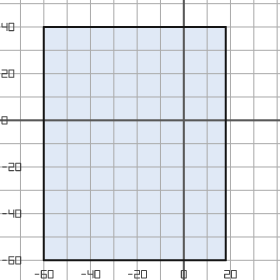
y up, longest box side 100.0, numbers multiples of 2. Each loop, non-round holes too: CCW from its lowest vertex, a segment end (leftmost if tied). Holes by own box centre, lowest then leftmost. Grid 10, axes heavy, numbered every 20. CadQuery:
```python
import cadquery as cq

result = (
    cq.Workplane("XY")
    .moveTo(-60.0, -60.0)
    .lineTo(18.0, -60.0)
    .lineTo(18.0, 40.0)
    .lineTo(-60.0, 40.0)
    .close()
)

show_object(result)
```